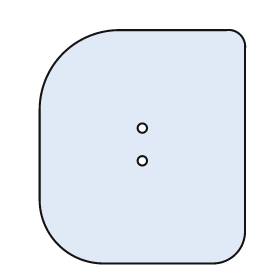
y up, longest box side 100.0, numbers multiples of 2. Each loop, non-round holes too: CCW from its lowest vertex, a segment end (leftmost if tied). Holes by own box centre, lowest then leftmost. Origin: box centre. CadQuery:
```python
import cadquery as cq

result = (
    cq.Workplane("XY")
    .moveTo(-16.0, -50.0)
    .lineTo(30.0, -50.0)
    .threePointArc((40.0, -46.0), (44.0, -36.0))
    .lineTo(44.0, 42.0)
    .threePointArc((42.0, 48.0), (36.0, 50.0))
    .lineTo(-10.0, 50.0)
    .threePointArc((-34.0, 40.0), (-44.0, 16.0))
    .lineTo(-44.0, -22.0)
    .threePointArc((-36.0, -42.0), (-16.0, -50.0))
    .close()
    .moveTo(0.0, -6.0)
    .circle(2.0)
    .moveTo(0.0, 8.0)
    .circle(2.0)
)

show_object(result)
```